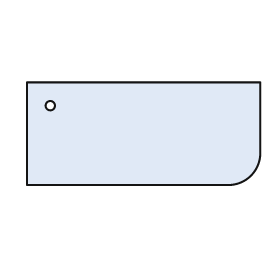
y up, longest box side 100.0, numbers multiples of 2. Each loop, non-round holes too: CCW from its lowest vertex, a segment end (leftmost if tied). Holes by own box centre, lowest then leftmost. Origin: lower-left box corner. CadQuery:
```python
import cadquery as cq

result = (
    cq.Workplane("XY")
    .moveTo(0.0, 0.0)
    .lineTo(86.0, 0.0)
    .threePointArc((96.0, 4.0), (100.0, 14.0))
    .lineTo(100.0, 44.0)
    .lineTo(0.0, 44.0)
    .close()
    .moveTo(10.0, 34.0)
    .circle(2.0)
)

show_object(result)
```